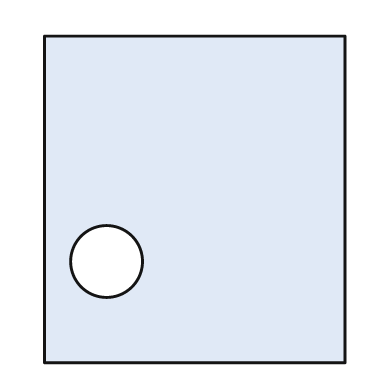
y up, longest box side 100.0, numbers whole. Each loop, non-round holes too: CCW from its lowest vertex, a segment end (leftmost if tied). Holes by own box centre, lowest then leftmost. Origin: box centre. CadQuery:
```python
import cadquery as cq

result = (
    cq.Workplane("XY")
    .moveTo(-46.0, -50.0)
    .lineTo(46.0, -50.0)
    .lineTo(46.0, 50.0)
    .lineTo(-46.0, 50.0)
    .close()
    .moveTo(-27.0, -19.0)
    .circle(11.0)
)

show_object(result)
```